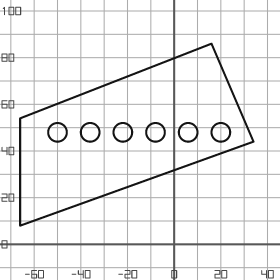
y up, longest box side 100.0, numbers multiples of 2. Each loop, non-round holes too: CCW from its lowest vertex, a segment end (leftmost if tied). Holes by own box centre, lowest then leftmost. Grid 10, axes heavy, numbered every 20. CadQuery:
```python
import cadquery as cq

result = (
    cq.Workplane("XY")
    .moveTo(-66.0, 8.0)
    .lineTo(34.0, 44.0)
    .lineTo(16.0, 86.0)
    .lineTo(-66.0, 54.0)
    .close()
    .moveTo(-50.0, 48.0)
    .circle(4.0)
    .moveTo(-36.0, 48.0)
    .circle(4.0)
    .moveTo(-22.0, 48.0)
    .circle(4.0)
    .moveTo(-8.0, 48.0)
    .circle(4.0)
    .moveTo(6.0, 48.0)
    .circle(4.0)
    .moveTo(20.0, 48.0)
    .circle(4.0)
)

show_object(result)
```